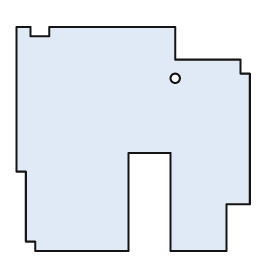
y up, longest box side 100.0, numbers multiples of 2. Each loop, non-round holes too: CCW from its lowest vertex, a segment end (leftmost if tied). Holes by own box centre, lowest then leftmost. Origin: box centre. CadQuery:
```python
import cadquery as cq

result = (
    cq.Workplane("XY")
    .moveTo(-42.0, -48.0)
    .lineTo(-2.0, -48.0)
    .lineTo(-2.0, -6.0)
    .lineTo(16.0, -6.0)
    .lineTo(16.0, -48.0)
    .lineTo(40.0, -48.0)
    .lineTo(40.0, -28.0)
    .lineTo(50.0, -28.0)
    .lineTo(50.0, 28.0)
    .lineTo(46.0, 28.0)
    .lineTo(46.0, 34.0)
    .lineTo(18.0, 34.0)
    .lineTo(18.0, 48.0)
    .lineTo(-36.0, 48.0)
    .lineTo(-36.0, 44.0)
    .lineTo(-44.0, 44.0)
    .lineTo(-44.0, 48.0)
    .lineTo(-50.0, 48.0)
    .lineTo(-50.0, -14.0)
    .lineTo(-46.0, -14.0)
    .lineTo(-46.0, -44.0)
    .lineTo(-42.0, -44.0)
    .close()
    .moveTo(18.0, 26.0)
    .circle(2.0)
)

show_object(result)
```